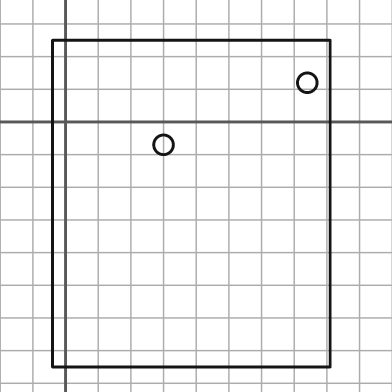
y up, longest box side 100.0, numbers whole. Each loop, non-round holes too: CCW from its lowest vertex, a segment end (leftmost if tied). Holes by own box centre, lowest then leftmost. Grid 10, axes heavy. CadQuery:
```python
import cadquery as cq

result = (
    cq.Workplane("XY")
    .moveTo(-4.0, -75.0)
    .lineTo(81.0, -75.0)
    .lineTo(81.0, 25.0)
    .lineTo(-4.0, 25.0)
    .close()
    .moveTo(30.0, -7.0)
    .circle(3.0)
    .moveTo(74.0, 12.0)
    .circle(3.0)
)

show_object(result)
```